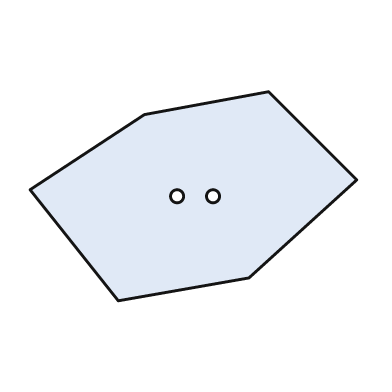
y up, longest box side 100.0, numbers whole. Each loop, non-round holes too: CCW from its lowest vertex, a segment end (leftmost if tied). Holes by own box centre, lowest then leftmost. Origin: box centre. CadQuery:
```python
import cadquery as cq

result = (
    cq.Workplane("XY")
    .moveTo(-23.0, -32.0)
    .lineTo(17.0, -25.0)
    .lineTo(50.0, 5.0)
    .lineTo(23.0, 32.0)
    .lineTo(-15.0, 25.0)
    .lineTo(-50.0, 2.0)
    .close()
    .moveTo(-5.0, 0.0)
    .circle(2.0)
    .moveTo(6.0, 0.0)
    .circle(2.0)
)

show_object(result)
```